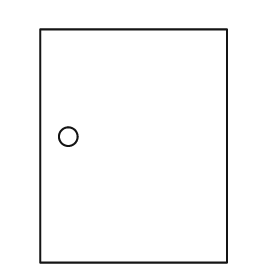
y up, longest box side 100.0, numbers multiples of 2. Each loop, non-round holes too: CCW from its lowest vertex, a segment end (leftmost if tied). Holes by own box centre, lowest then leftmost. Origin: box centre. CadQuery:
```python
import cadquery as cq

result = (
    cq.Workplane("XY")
    .moveTo(-40.0, -50.0)
    .lineTo(40.0, -50.0)
    .lineTo(40.0, 50.0)
    .lineTo(-40.0, 50.0)
    .close()
    .moveTo(-28.0, 4.0)
    .circle(4.0)
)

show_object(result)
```